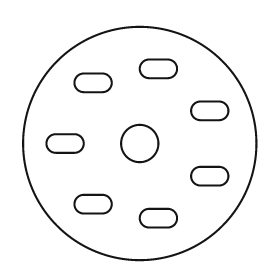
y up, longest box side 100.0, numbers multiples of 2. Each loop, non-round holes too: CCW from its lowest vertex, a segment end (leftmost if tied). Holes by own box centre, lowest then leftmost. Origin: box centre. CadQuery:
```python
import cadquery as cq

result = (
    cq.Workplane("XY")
    .moveTo(0.0, 0.0)
    .circle(50.0)
    .moveTo(4.0, -36.0)
    .lineTo(12.0, -36.0)
    .threePointArc((16.0, -32.0), (12.0, -28.0))
    .lineTo(4.0, -28.0)
    .threePointArc((0.0, -32.0), (4.0, -36.0))
    .close()
    .moveTo(-24.0, -30.0)
    .lineTo(-16.0, -30.0)
    .threePointArc((-12.0, -26.0), (-16.0, -22.0))
    .lineTo(-24.0, -22.0)
    .threePointArc((-28.0, -26.0), (-24.0, -30.0))
    .close()
    .moveTo(26.0, -18.0)
    .lineTo(34.0, -18.0)
    .threePointArc((38.0, -14.0), (34.0, -10.0))
    .lineTo(26.0, -10.0)
    .threePointArc((22.0, -14.0), (26.0, -18.0))
    .close()
    .moveTo(-36.0, -4.0)
    .lineTo(-28.0, -4.0)
    .threePointArc((-24.0, 0.0), (-28.0, 4.0))
    .lineTo(-36.0, 4.0)
    .threePointArc((-40.0, 0.0), (-36.0, -4.0))
    .close()
    .moveTo(0.0, 0.0)
    .circle(8.0)
    .moveTo(26.0, 10.0)
    .lineTo(34.0, 10.0)
    .threePointArc((38.0, 14.0), (34.0, 18.0))
    .lineTo(26.0, 18.0)
    .threePointArc((22.0, 14.0), (26.0, 10.0))
    .close()
    .moveTo(-24.0, 22.0)
    .lineTo(-16.0, 22.0)
    .threePointArc((-12.0, 26.0), (-16.0, 30.0))
    .lineTo(-24.0, 30.0)
    .threePointArc((-28.0, 26.0), (-24.0, 22.0))
    .close()
    .moveTo(4.0, 28.0)
    .lineTo(12.0, 28.0)
    .threePointArc((16.0, 32.0), (12.0, 36.0))
    .lineTo(4.0, 36.0)
    .threePointArc((0.0, 32.0), (4.0, 28.0))
    .close()
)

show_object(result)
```